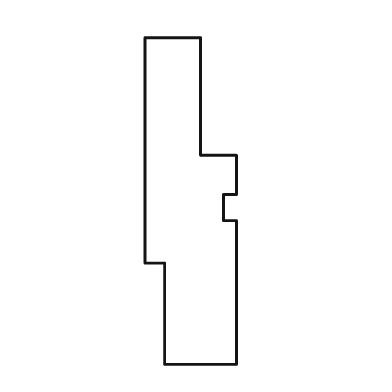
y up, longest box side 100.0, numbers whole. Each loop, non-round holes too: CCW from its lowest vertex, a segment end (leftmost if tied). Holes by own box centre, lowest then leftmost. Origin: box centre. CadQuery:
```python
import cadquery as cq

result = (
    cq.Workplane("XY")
    .moveTo(-8.0, -50.0)
    .lineTo(14.0, -50.0)
    .lineTo(14.0, -6.0)
    .lineTo(10.0, -6.0)
    .lineTo(10.0, 2.0)
    .lineTo(14.0, 2.0)
    .lineTo(14.0, 14.0)
    .lineTo(3.0, 14.0)
    .lineTo(3.0, 50.0)
    .lineTo(-14.0, 50.0)
    .lineTo(-14.0, -19.0)
    .lineTo(-8.0, -19.0)
    .close()
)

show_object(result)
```